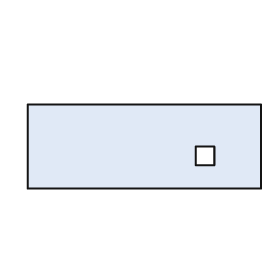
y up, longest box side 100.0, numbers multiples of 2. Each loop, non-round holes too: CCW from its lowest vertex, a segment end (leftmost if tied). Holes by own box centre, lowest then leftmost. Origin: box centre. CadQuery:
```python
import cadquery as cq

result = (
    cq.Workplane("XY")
    .moveTo(-50.0, -18.0)
    .lineTo(50.0, -18.0)
    .lineTo(50.0, 18.0)
    .lineTo(-50.0, 18.0)
    .close()
    .moveTo(22.0, -8.0)
    .lineTo(30.0, -8.0)
    .lineTo(30.0, 0.0)
    .lineTo(22.0, 0.0)
    .close()
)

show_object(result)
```